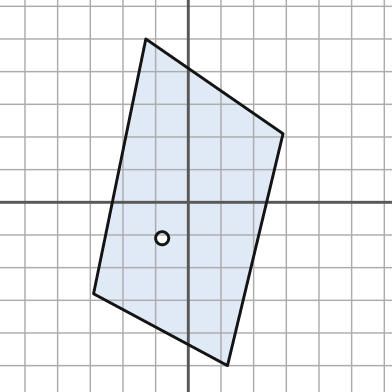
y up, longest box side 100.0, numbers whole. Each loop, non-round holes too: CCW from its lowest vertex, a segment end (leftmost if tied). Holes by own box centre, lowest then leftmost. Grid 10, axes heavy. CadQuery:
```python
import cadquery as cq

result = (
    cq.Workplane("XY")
    .moveTo(12.0, -50.0)
    .lineTo(29.0, 21.0)
    .lineTo(-13.0, 50.0)
    .lineTo(-29.0, -28.0)
    .close()
    .moveTo(-8.0, -11.0)
    .circle(2.0)
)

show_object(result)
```